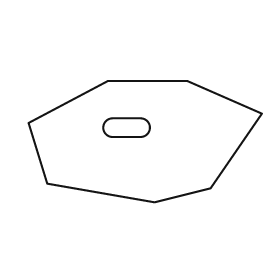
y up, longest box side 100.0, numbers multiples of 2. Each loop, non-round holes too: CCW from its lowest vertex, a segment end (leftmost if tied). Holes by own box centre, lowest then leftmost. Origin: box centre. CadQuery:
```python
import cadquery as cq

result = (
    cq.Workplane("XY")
    .moveTo(4.0, -26.0)
    .lineTo(28.0, -20.0)
    .lineTo(50.0, 12.0)
    .lineTo(18.0, 26.0)
    .lineTo(-16.0, 26.0)
    .lineTo(-50.0, 8.0)
    .lineTo(-42.0, -18.0)
    .close()
    .moveTo(-14.0, 2.0)
    .lineTo(-2.0, 2.0)
    .threePointArc((2.0, 6.0), (-2.0, 10.0))
    .lineTo(-14.0, 10.0)
    .threePointArc((-18.0, 6.0), (-14.0, 2.0))
    .close()
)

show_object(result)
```